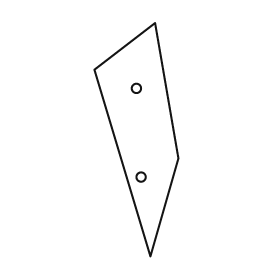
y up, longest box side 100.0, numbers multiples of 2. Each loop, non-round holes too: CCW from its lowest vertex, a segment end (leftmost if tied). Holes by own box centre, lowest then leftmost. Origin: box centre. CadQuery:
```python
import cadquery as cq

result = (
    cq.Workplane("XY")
    .moveTo(6.0, -50.0)
    .lineTo(18.0, -8.0)
    .lineTo(8.0, 50.0)
    .lineTo(-18.0, 30.0)
    .close()
    .moveTo(2.0, -16.0)
    .circle(2.0)
    .moveTo(0.0, 22.0)
    .circle(2.0)
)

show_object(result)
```